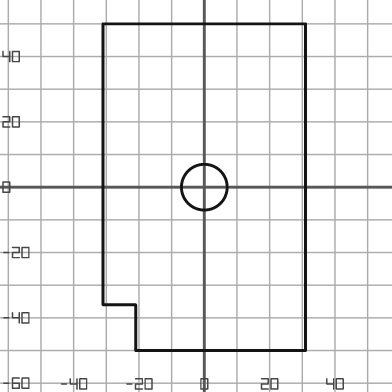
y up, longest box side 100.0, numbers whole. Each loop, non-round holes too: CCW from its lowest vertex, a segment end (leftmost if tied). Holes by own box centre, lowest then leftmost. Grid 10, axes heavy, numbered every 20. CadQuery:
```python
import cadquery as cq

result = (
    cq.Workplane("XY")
    .moveTo(-21.0, -50.0)
    .lineTo(31.0, -50.0)
    .lineTo(31.0, 50.0)
    .lineTo(-31.0, 50.0)
    .lineTo(-31.0, -36.0)
    .lineTo(-21.0, -36.0)
    .close()
    .moveTo(0.0, 0.0)
    .circle(7.0)
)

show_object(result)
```